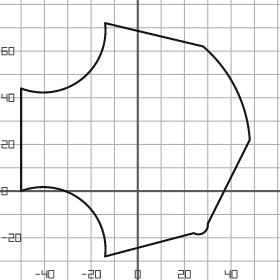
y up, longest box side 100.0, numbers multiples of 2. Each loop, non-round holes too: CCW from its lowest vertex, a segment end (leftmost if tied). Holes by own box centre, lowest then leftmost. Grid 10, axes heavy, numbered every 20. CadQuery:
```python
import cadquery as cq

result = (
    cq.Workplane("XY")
    .moveTo(-14.0, -28.0)
    .lineTo(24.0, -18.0)
    .threePointArc((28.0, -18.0), (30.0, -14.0))
    .lineTo(48.0, 22.0)
    .threePointArc((42.0, 44.0), (28.0, 62.0))
    .lineTo(-14.0, 72.0)
    .threePointArc((-24.0, 48.0), (-50.0, 44.0))
    .lineTo(-50.0, 0.0)
    .threePointArc((-24.0, -4.0), (-14.0, -28.0))
    .close()
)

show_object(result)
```